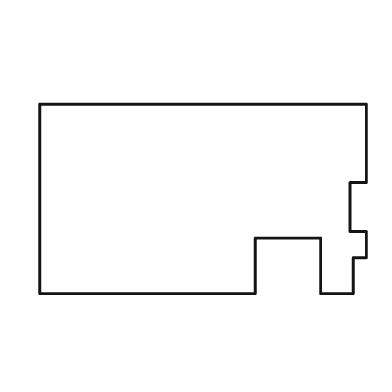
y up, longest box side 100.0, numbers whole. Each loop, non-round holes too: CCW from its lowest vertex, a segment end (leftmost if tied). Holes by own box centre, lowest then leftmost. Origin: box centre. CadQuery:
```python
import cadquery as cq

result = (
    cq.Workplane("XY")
    .moveTo(-50.0, -29.0)
    .lineTo(16.0, -29.0)
    .lineTo(16.0, -12.0)
    .lineTo(36.0, -12.0)
    .lineTo(36.0, -29.0)
    .lineTo(46.0, -29.0)
    .lineTo(46.0, -18.0)
    .lineTo(50.0, -18.0)
    .lineTo(50.0, -10.0)
    .lineTo(45.0, -10.0)
    .lineTo(45.0, 5.0)
    .lineTo(50.0, 5.0)
    .lineTo(50.0, 29.0)
    .lineTo(-50.0, 29.0)
    .close()
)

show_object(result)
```